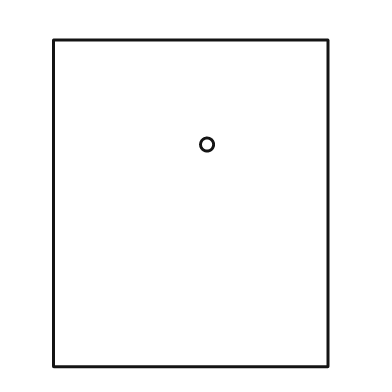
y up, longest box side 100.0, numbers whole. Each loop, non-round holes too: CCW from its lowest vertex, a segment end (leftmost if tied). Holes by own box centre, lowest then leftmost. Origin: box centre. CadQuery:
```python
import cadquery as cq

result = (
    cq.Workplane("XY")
    .moveTo(-42.0, -50.0)
    .lineTo(42.0, -50.0)
    .lineTo(42.0, 50.0)
    .lineTo(-42.0, 50.0)
    .close()
    .moveTo(5.0, 18.0)
    .circle(2.0)
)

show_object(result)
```